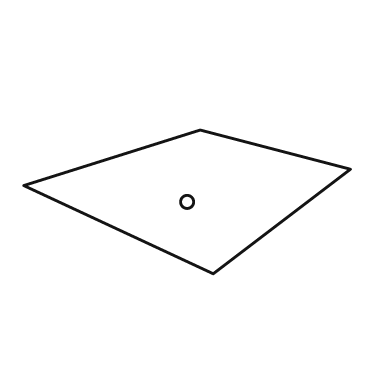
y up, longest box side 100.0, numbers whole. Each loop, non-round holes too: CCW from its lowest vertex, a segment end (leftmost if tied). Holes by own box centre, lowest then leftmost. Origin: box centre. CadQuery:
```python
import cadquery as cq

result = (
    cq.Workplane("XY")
    .moveTo(8.0, -22.0)
    .lineTo(50.0, 10.0)
    .lineTo(4.0, 22.0)
    .lineTo(-50.0, 5.0)
    .close()
    .moveTo(0.0, 0.0)
    .circle(2.0)
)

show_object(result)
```